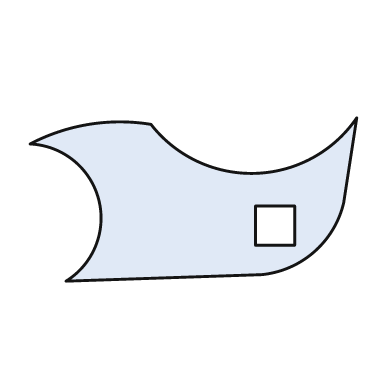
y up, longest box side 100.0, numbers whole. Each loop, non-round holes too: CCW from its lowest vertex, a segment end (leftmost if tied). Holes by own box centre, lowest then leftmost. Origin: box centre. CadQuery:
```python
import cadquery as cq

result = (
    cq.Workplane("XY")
    .moveTo(-39.0, -25.0)
    .lineTo(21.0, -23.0)
    .threePointArc((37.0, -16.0), (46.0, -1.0))
    .lineTo(50.0, 25.0)
    .threePointArc((19.0, 8.0), (-13.0, 23.0))
    .threePointArc((-32.0, 23.0), (-50.0, 17.0))
    .threePointArc((-29.0, 0.0), (-39.0, -25.0))
    .close()
    .moveTo(19.0, -14.0)
    .lineTo(31.0, -14.0)
    .lineTo(31.0, -2.0)
    .lineTo(19.0, -2.0)
    .close()
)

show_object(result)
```